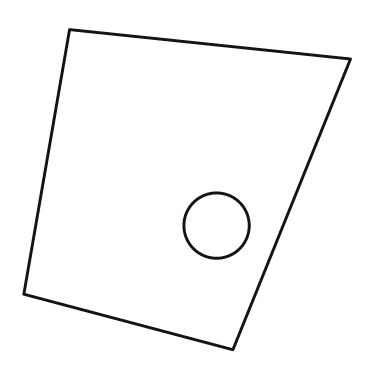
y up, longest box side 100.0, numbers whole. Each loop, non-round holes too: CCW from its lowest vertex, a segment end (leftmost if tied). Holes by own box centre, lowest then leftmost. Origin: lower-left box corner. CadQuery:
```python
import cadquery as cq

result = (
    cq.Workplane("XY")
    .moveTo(64.0, 0.0)
    .lineTo(100.0, 89.0)
    .lineTo(14.0, 98.0)
    .lineTo(0.0, 17.0)
    .close()
    .moveTo(59.0, 38.0)
    .circle(10.0)
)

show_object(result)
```